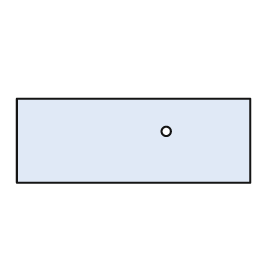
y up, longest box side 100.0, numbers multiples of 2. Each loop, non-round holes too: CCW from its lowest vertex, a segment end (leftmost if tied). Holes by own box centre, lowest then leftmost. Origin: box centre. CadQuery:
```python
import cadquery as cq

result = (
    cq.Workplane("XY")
    .moveTo(-50.0, -18.0)
    .lineTo(50.0, -18.0)
    .lineTo(50.0, 18.0)
    .lineTo(-50.0, 18.0)
    .close()
    .moveTo(14.0, 4.0)
    .circle(2.0)
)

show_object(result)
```